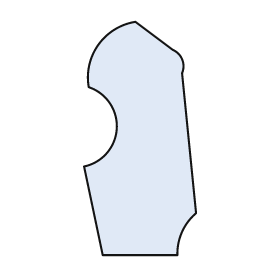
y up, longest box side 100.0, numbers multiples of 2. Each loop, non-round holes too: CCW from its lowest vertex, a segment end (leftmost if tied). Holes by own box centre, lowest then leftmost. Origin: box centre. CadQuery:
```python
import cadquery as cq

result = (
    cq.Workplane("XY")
    .moveTo(-16.0, -50.0)
    .lineTo(16.0, -50.0)
    .threePointArc((18.0, -40.0), (24.0, -32.0))
    .lineTo(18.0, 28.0)
    .threePointArc((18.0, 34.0), (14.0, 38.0))
    .lineTo(-2.0, 50.0)
    .threePointArc((-18.0, 40.0), (-22.0, 22.0))
    .threePointArc((-10.0, 4.0), (-24.0, -12.0))
    .close()
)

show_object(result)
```